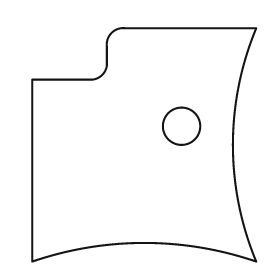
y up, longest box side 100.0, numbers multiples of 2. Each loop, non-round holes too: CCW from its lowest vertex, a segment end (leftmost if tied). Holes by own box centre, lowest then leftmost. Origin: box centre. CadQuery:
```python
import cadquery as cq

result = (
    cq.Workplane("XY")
    .moveTo(-48.0, -50.0)
    .threePointArc((0.0, -42.0), (48.0, -50.0))
    .threePointArc((38.0, 0.0), (48.0, 50.0))
    .lineTo(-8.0, 50.0)
    .threePointArc((-14.0, 48.0), (-16.0, 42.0))
    .lineTo(-16.0, 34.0)
    .threePointArc((-18.0, 30.0), (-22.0, 28.0))
    .lineTo(-48.0, 28.0)
    .close()
    .moveTo(16.0, 8.0)
    .circle(8.0)
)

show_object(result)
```